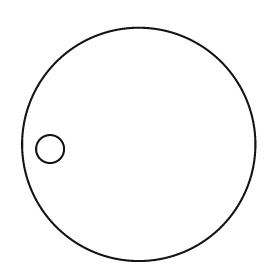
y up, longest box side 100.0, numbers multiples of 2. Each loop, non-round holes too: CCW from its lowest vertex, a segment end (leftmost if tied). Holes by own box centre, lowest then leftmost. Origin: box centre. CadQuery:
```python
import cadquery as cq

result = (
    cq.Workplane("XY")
    .moveTo(0.0, 0.0)
    .circle(50.0)
    .moveTo(-38.0, -2.0)
    .circle(6.0)
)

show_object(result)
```